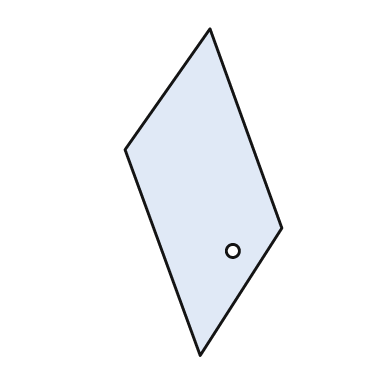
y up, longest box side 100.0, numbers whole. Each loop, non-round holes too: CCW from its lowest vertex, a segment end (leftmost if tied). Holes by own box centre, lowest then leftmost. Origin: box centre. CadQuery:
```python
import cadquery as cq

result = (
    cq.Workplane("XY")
    .moveTo(-1.0, -50.0)
    .lineTo(24.0, -11.0)
    .lineTo(2.0, 50.0)
    .lineTo(-24.0, 13.0)
    .close()
    .moveTo(9.0, -18.0)
    .circle(2.0)
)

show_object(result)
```